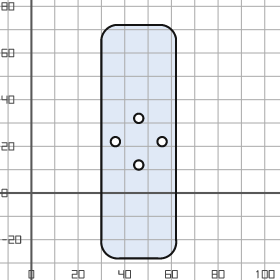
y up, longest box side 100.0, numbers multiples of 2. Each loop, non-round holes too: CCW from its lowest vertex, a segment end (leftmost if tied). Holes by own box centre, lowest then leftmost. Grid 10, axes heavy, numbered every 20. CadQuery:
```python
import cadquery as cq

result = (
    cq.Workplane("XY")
    .moveTo(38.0, -28.0)
    .lineTo(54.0, -28.0)
    .threePointArc((60.0, -26.0), (62.0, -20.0))
    .lineTo(62.0, 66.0)
    .threePointArc((60.0, 70.0), (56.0, 72.0))
    .lineTo(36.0, 72.0)
    .threePointArc((32.0, 70.0), (30.0, 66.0))
    .lineTo(30.0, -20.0)
    .threePointArc((32.0, -26.0), (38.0, -28.0))
    .close()
    .moveTo(46.0, 12.0)
    .circle(2.0)
    .moveTo(36.0, 22.0)
    .circle(2.0)
    .moveTo(56.0, 22.0)
    .circle(2.0)
    .moveTo(46.0, 32.0)
    .circle(2.0)
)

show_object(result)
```